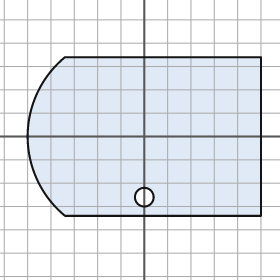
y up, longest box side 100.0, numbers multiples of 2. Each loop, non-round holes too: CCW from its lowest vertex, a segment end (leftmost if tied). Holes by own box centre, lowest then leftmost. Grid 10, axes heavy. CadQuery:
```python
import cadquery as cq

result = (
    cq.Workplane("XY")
    .moveTo(-34.0, -34.0)
    .lineTo(50.0, -34.0)
    .lineTo(50.0, 34.0)
    .lineTo(-34.0, 34.0)
    .threePointArc((-50.0, 0.0), (-34.0, -34.0))
    .close()
    .moveTo(0.0, -26.0)
    .circle(4.0)
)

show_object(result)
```